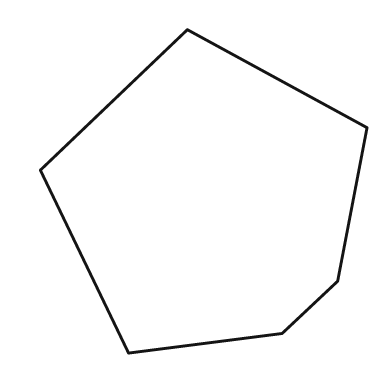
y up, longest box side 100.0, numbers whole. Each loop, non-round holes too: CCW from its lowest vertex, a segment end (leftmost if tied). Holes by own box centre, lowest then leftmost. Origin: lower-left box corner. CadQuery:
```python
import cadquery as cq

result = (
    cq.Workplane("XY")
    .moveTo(27.0, 0.0)
    .lineTo(74.0, 6.0)
    .lineTo(91.0, 22.0)
    .lineTo(100.0, 69.0)
    .lineTo(45.0, 99.0)
    .lineTo(0.0, 56.0)
    .close()
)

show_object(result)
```